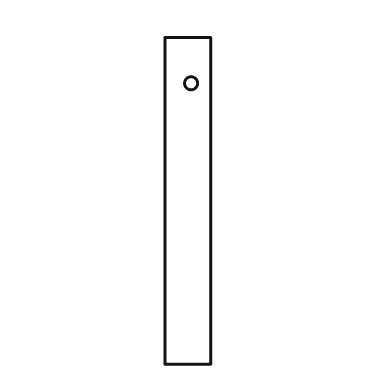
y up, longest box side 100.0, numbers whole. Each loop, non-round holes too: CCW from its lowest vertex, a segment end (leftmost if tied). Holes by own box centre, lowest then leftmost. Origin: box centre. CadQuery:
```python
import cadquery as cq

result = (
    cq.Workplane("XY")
    .moveTo(-7.0, -50.0)
    .lineTo(7.0, -50.0)
    .lineTo(7.0, 50.0)
    .lineTo(-7.0, 50.0)
    .close()
    .moveTo(1.0, 36.0)
    .circle(2.0)
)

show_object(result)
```